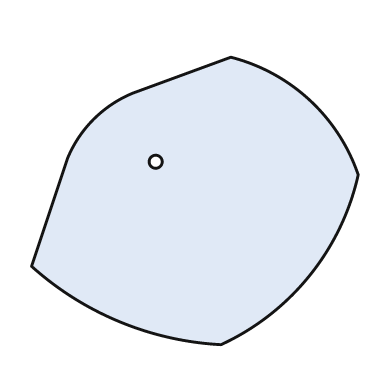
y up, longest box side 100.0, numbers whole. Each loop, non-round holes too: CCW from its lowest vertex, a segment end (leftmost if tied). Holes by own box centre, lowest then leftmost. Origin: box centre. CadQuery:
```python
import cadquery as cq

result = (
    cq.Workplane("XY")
    .moveTo(8.0, -44.0)
    .threePointArc((35.0, -23.0), (50.0, 8.0))
    .threePointArc((35.0, 31.0), (11.0, 44.0))
    .lineTo(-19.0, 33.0)
    .threePointArc((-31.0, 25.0), (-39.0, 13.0))
    .lineTo(-50.0, -20.0)
    .threePointArc((-23.0, -37.0), (8.0, -44.0))
    .close()
    .moveTo(-12.0, 12.0)
    .circle(2.0)
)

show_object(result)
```